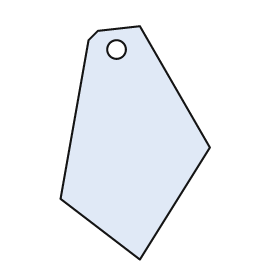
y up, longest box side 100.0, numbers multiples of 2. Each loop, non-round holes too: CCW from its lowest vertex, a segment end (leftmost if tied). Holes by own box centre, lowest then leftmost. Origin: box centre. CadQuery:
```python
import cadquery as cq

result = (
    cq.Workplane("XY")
    .moveTo(2.0, -50.0)
    .lineTo(32.0, -2.0)
    .lineTo(2.0, 50.0)
    .lineTo(-16.0, 48.0)
    .lineTo(-20.0, 44.0)
    .lineTo(-32.0, -24.0)
    .close()
    .moveTo(-8.0, 40.0)
    .circle(4.0)
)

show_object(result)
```